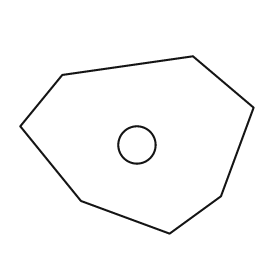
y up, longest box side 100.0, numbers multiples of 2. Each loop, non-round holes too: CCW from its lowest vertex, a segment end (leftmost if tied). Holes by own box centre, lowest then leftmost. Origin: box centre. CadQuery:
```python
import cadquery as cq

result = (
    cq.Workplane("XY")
    .moveTo(14.0, -38.0)
    .lineTo(36.0, -22.0)
    .lineTo(50.0, 16.0)
    .lineTo(24.0, 38.0)
    .lineTo(-32.0, 30.0)
    .lineTo(-50.0, 8.0)
    .lineTo(-24.0, -24.0)
    .close()
    .moveTo(0.0, 0.0)
    .circle(8.0)
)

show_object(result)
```